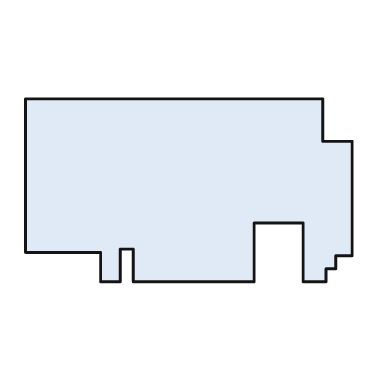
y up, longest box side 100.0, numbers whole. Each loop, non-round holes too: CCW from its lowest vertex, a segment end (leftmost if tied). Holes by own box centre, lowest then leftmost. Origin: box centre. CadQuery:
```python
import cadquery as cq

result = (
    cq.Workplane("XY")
    .moveTo(-27.0, -28.0)
    .lineTo(-21.0, -28.0)
    .lineTo(-21.0, -18.0)
    .lineTo(-17.0, -18.0)
    .lineTo(-17.0, -28.0)
    .lineTo(20.0, -28.0)
    .lineTo(20.0, -10.0)
    .lineTo(35.0, -10.0)
    .lineTo(35.0, -28.0)
    .lineTo(42.0, -28.0)
    .lineTo(42.0, -24.0)
    .lineTo(45.0, -24.0)
    .lineTo(45.0, -20.0)
    .lineTo(50.0, -20.0)
    .lineTo(50.0, 15.0)
    .lineTo(41.0, 15.0)
    .lineTo(41.0, 28.0)
    .lineTo(-50.0, 28.0)
    .lineTo(-50.0, -19.0)
    .lineTo(-27.0, -19.0)
    .close()
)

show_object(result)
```